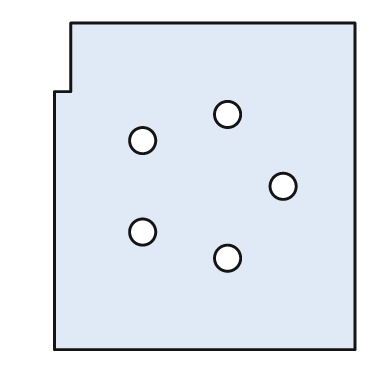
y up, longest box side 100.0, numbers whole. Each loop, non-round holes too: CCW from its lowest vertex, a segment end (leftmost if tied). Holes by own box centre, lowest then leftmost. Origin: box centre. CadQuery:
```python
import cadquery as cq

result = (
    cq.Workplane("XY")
    .moveTo(-46.0, -50.0)
    .lineTo(46.0, -50.0)
    .lineTo(46.0, 50.0)
    .lineTo(-41.0, 50.0)
    .lineTo(-41.0, 29.0)
    .lineTo(-46.0, 29.0)
    .close()
    .moveTo(7.0, -22.0)
    .circle(4.0)
    .moveTo(-19.0, -14.0)
    .circle(4.0)
    .moveTo(24.0, 0.0)
    .circle(4.0)
    .moveTo(-19.0, 14.0)
    .circle(4.0)
    .moveTo(7.0, 22.0)
    .circle(4.0)
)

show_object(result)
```